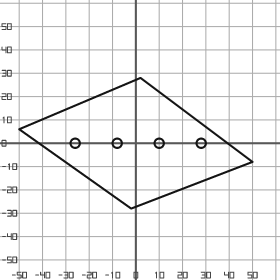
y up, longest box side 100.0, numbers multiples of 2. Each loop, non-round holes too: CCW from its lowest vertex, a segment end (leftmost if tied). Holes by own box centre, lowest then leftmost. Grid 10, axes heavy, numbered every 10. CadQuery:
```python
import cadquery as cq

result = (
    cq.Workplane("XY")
    .moveTo(-2.0, -28.0)
    .lineTo(50.0, -8.0)
    .lineTo(2.0, 28.0)
    .lineTo(-50.0, 6.0)
    .close()
    .moveTo(-26.0, 0.0)
    .circle(2.0)
    .moveTo(-8.0, 0.0)
    .circle(2.0)
    .moveTo(10.0, 0.0)
    .circle(2.0)
    .moveTo(28.0, 0.0)
    .circle(2.0)
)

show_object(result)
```